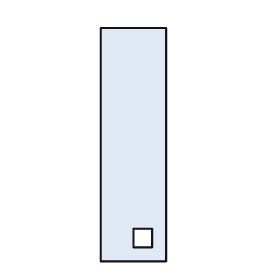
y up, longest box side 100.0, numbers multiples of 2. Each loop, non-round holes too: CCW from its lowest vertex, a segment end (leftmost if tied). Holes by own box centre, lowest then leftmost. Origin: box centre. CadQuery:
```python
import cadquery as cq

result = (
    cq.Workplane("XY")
    .moveTo(-14.0, -50.0)
    .lineTo(14.0, -50.0)
    .lineTo(14.0, 50.0)
    .lineTo(-14.0, 50.0)
    .close()
    .moveTo(0.0, -44.0)
    .lineTo(8.0, -44.0)
    .lineTo(8.0, -36.0)
    .lineTo(0.0, -36.0)
    .close()
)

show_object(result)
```